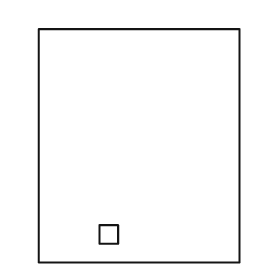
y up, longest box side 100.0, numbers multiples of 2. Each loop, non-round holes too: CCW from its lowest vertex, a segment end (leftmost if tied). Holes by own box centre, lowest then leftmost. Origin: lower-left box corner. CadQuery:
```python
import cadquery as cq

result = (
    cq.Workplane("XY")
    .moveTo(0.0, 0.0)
    .lineTo(86.0, 0.0)
    .lineTo(86.0, 100.0)
    .lineTo(0.0, 100.0)
    .close()
    .moveTo(26.0, 8.0)
    .lineTo(34.0, 8.0)
    .lineTo(34.0, 16.0)
    .lineTo(26.0, 16.0)
    .close()
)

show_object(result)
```